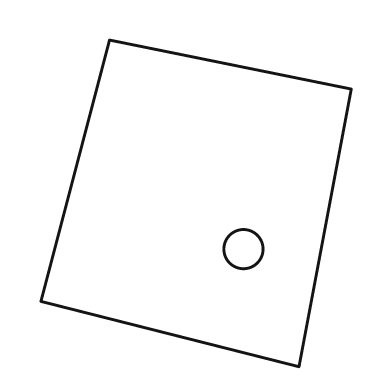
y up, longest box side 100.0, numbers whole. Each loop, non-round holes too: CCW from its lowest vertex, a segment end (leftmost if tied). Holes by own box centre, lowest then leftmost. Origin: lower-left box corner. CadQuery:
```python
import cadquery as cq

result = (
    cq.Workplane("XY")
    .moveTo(79.0, 0.0)
    .lineTo(95.0, 85.0)
    .lineTo(21.0, 100.0)
    .lineTo(0.0, 20.0)
    .close()
    .moveTo(62.0, 36.0)
    .circle(6.0)
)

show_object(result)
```